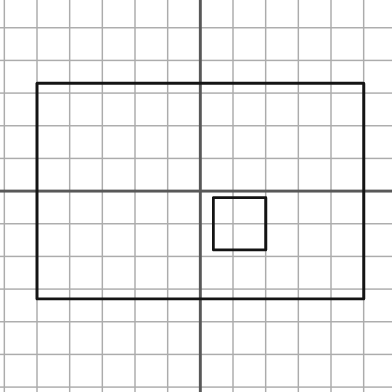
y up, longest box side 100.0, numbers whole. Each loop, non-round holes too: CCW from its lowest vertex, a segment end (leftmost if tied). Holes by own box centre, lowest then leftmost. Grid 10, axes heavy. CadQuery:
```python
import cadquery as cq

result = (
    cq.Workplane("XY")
    .moveTo(-50.0, -33.0)
    .lineTo(50.0, -33.0)
    .lineTo(50.0, 33.0)
    .lineTo(-50.0, 33.0)
    .close()
    .moveTo(4.0, -18.0)
    .lineTo(20.0, -18.0)
    .lineTo(20.0, -2.0)
    .lineTo(4.0, -2.0)
    .close()
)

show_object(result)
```